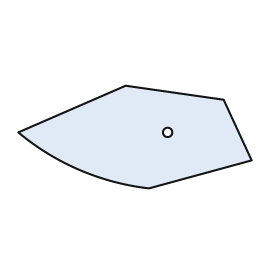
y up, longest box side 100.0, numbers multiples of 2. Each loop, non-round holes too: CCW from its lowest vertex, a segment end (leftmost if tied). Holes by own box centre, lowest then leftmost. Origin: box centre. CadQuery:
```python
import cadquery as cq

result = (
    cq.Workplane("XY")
    .moveTo(6.0, -22.0)
    .lineTo(50.0, -10.0)
    .lineTo(38.0, 16.0)
    .lineTo(-4.0, 22.0)
    .lineTo(-50.0, 2.0)
    .threePointArc((-24.0, -14.0), (6.0, -22.0))
    .close()
    .moveTo(14.0, 2.0)
    .circle(2.0)
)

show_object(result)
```